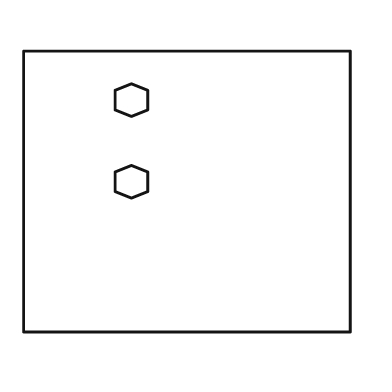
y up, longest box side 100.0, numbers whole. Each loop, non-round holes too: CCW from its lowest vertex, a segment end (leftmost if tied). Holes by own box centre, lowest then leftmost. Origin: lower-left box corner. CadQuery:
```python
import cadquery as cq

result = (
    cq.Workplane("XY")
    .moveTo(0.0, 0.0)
    .lineTo(100.0, 0.0)
    .lineTo(100.0, 86.0)
    .lineTo(0.0, 86.0)
    .close()
    .moveTo(33.0, 41.0)
    .lineTo(38.0, 43.0)
    .lineTo(38.0, 49.0)
    .lineTo(33.0, 51.0)
    .lineTo(28.0, 49.0)
    .lineTo(28.0, 43.0)
    .close()
    .moveTo(33.0, 66.0)
    .lineTo(38.0, 68.0)
    .lineTo(38.0, 74.0)
    .lineTo(33.0, 76.0)
    .lineTo(28.0, 74.0)
    .lineTo(28.0, 68.0)
    .close()
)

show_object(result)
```